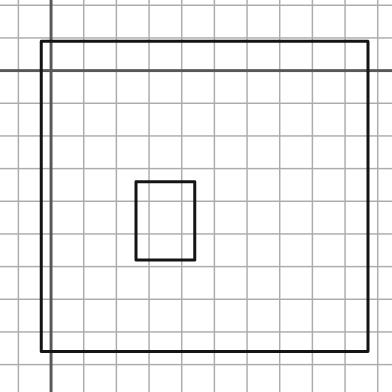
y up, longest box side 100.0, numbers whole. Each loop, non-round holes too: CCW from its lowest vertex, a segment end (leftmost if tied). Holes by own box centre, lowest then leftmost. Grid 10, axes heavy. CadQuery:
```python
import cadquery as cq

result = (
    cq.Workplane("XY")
    .moveTo(-3.0, -86.0)
    .lineTo(97.0, -86.0)
    .lineTo(97.0, 9.0)
    .lineTo(-3.0, 9.0)
    .close()
    .moveTo(26.0, -58.0)
    .lineTo(44.0, -58.0)
    .lineTo(44.0, -34.0)
    .lineTo(26.0, -34.0)
    .close()
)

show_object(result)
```